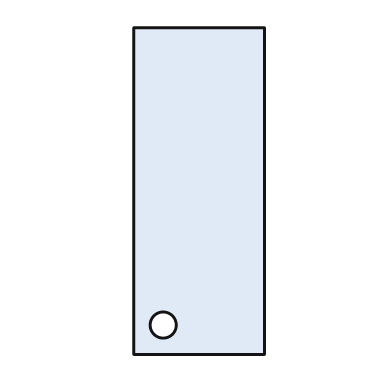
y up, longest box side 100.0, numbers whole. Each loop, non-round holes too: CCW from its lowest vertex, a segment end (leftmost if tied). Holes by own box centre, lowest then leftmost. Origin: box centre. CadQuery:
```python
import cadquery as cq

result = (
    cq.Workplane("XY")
    .moveTo(-20.0, -50.0)
    .lineTo(20.0, -50.0)
    .lineTo(20.0, 50.0)
    .lineTo(-20.0, 50.0)
    .close()
    .moveTo(-11.0, -41.0)
    .circle(4.0)
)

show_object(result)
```